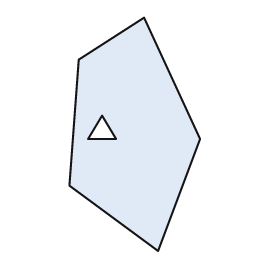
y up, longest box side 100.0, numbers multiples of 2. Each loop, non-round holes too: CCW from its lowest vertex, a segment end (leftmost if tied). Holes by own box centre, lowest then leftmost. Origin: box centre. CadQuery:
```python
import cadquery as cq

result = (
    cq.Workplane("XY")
    .moveTo(10.0, -50.0)
    .lineTo(28.0, -2.0)
    .lineTo(4.0, 50.0)
    .lineTo(-24.0, 32.0)
    .lineTo(-28.0, -22.0)
    .close()
    .moveTo(-20.0, -2.0)
    .lineTo(-8.0, -2.0)
    .lineTo(-14.0, 8.0)
    .close()
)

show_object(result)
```